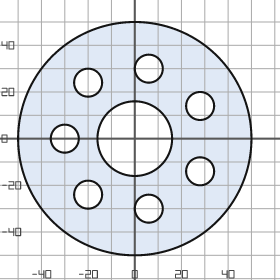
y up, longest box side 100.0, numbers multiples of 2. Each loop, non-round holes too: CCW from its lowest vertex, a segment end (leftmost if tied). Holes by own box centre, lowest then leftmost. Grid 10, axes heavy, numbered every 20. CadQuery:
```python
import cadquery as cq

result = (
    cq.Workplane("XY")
    .moveTo(0.0, 0.0)
    .circle(50.0)
    .moveTo(6.0, -30.0)
    .circle(6.0)
    .moveTo(-20.0, -24.0)
    .circle(6.0)
    .moveTo(28.0, -14.0)
    .circle(6.0)
    .moveTo(-30.0, 0.0)
    .circle(6.0)
    .moveTo(0.0, 0.0)
    .circle(16.0)
    .moveTo(28.0, 14.0)
    .circle(6.0)
    .moveTo(-20.0, 24.0)
    .circle(6.0)
    .moveTo(6.0, 30.0)
    .circle(6.0)
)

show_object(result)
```